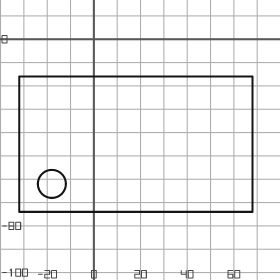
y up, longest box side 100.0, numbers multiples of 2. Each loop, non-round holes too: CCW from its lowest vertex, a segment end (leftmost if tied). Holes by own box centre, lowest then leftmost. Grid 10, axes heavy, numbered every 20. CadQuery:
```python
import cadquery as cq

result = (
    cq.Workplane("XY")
    .moveTo(-32.0, -74.0)
    .lineTo(68.0, -74.0)
    .lineTo(68.0, -16.0)
    .lineTo(-32.0, -16.0)
    .close()
    .moveTo(-18.0, -62.0)
    .circle(6.0)
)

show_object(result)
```